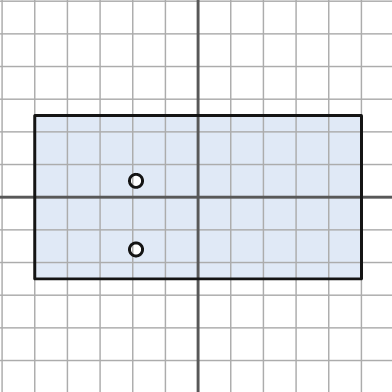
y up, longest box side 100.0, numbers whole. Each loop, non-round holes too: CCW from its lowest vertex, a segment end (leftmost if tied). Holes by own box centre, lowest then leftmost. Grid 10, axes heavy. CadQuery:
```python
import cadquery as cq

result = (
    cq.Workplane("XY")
    .moveTo(-50.0, -25.0)
    .lineTo(50.0, -25.0)
    .lineTo(50.0, 25.0)
    .lineTo(-50.0, 25.0)
    .close()
    .moveTo(-19.0, -16.0)
    .circle(2.0)
    .moveTo(-19.0, 5.0)
    .circle(2.0)
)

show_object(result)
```